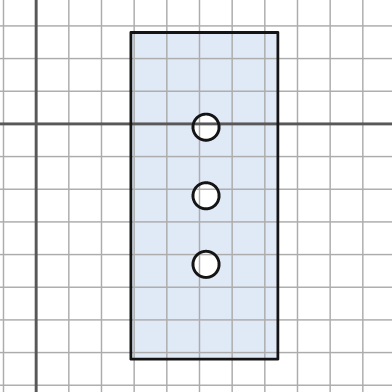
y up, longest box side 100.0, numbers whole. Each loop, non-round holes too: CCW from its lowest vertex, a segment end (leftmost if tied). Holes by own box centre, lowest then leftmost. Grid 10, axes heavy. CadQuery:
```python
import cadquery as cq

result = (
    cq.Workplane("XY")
    .moveTo(29.0, -72.0)
    .lineTo(74.0, -72.0)
    .lineTo(74.0, 28.0)
    .lineTo(29.0, 28.0)
    .close()
    .moveTo(52.0, -43.0)
    .circle(4.0)
    .moveTo(52.0, -22.0)
    .circle(4.0)
    .moveTo(52.0, -1.0)
    .circle(4.0)
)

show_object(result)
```